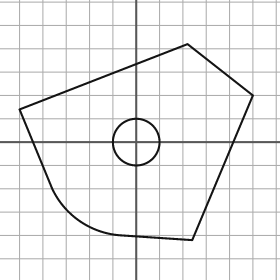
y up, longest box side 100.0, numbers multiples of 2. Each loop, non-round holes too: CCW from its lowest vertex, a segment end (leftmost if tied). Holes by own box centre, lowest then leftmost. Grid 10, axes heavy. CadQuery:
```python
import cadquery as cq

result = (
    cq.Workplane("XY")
    .moveTo(24.0, -42.0)
    .lineTo(50.0, 20.0)
    .lineTo(22.0, 42.0)
    .lineTo(-50.0, 14.0)
    .lineTo(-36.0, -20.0)
    .threePointArc((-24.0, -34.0), (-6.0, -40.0))
    .close()
    .moveTo(0.0, 0.0)
    .circle(10.0)
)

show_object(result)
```